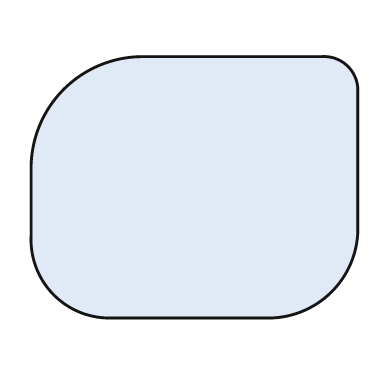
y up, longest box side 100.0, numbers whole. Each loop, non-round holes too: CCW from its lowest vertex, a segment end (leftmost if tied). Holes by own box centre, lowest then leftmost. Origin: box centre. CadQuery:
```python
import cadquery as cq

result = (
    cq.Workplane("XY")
    .moveTo(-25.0, -40.0)
    .lineTo(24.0, -40.0)
    .threePointArc((42.0, -32.0), (50.0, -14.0))
    .lineTo(50.0, 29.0)
    .threePointArc((47.0, 37.0), (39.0, 40.0))
    .lineTo(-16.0, 40.0)
    .threePointArc((-40.0, 30.0), (-50.0, 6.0))
    .lineTo(-50.0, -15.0)
    .threePointArc((-43.0, -33.0), (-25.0, -40.0))
    .close()
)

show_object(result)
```